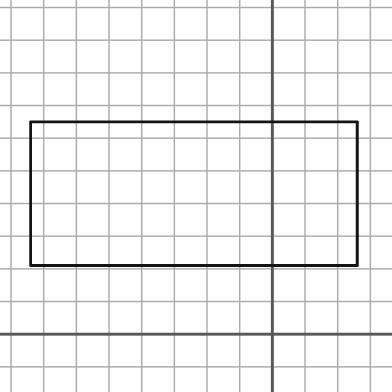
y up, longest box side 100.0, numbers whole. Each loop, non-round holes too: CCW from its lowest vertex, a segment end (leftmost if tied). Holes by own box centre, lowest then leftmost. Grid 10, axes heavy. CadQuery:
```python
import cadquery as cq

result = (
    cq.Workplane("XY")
    .moveTo(-74.0, 21.0)
    .lineTo(26.0, 21.0)
    .lineTo(26.0, 65.0)
    .lineTo(-74.0, 65.0)
    .close()
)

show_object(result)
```